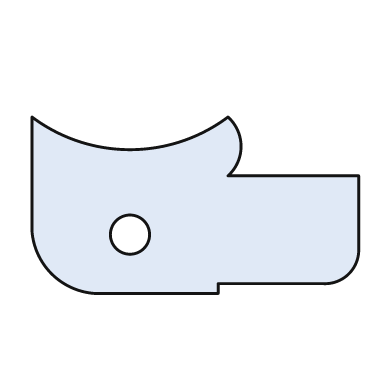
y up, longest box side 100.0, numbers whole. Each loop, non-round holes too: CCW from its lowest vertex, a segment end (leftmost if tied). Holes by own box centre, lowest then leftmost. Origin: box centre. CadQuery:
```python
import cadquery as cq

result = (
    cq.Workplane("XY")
    .moveTo(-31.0, -27.0)
    .lineTo(7.0, -27.0)
    .lineTo(7.0, -24.0)
    .lineTo(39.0, -24.0)
    .threePointArc((47.0, -21.0), (50.0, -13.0))
    .lineTo(50.0, 9.0)
    .lineTo(10.0, 9.0)
    .threePointArc((14.0, 18.0), (10.0, 27.0))
    .threePointArc((-20.0, 17.0), (-50.0, 27.0))
    .lineTo(-50.0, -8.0)
    .threePointArc((-44.0, -21.0), (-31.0, -27.0))
    .close()
    .moveTo(-20.0, -9.0)
    .circle(6.0)
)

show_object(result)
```